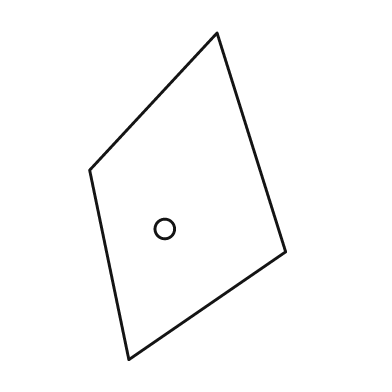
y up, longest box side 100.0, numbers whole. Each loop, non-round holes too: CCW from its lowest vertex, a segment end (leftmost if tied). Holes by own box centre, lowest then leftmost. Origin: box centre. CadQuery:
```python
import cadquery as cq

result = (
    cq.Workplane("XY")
    .moveTo(-18.0, -50.0)
    .lineTo(30.0, -17.0)
    .lineTo(9.0, 50.0)
    .lineTo(-30.0, 8.0)
    .close()
    .moveTo(-7.0, -10.0)
    .circle(3.0)
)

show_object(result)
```